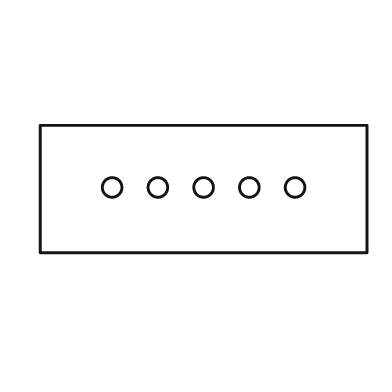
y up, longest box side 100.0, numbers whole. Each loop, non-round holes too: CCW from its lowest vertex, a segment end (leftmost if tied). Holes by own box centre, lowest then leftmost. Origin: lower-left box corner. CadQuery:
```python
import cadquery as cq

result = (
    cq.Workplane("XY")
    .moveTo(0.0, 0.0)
    .lineTo(100.0, 0.0)
    .lineTo(100.0, 39.0)
    .lineTo(0.0, 39.0)
    .close()
    .moveTo(22.0, 20.0)
    .circle(3.0)
    .moveTo(36.0, 20.0)
    .circle(3.0)
    .moveTo(50.0, 20.0)
    .circle(3.0)
    .moveTo(64.0, 20.0)
    .circle(3.0)
    .moveTo(78.0, 20.0)
    .circle(3.0)
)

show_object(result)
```